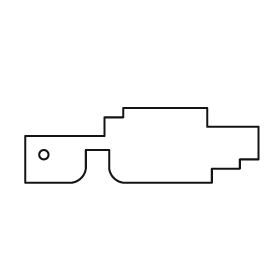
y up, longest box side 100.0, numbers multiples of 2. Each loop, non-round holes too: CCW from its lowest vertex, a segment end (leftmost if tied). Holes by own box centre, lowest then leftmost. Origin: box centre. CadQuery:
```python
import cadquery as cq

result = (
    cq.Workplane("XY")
    .moveTo(-50.0, -16.0)
    .lineTo(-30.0, -16.0)
    .threePointArc((-26.0, -14.0), (-24.0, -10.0))
    .lineTo(-24.0, -2.0)
    .lineTo(-14.0, -2.0)
    .lineTo(-14.0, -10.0)
    .threePointArc((-12.0, -14.0), (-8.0, -16.0))
    .lineTo(30.0, -16.0)
    .lineTo(30.0, -10.0)
    .lineTo(42.0, -10.0)
    .lineTo(42.0, -6.0)
    .lineTo(50.0, -6.0)
    .lineTo(50.0, 8.0)
    .lineTo(28.0, 8.0)
    .lineTo(28.0, 16.0)
    .lineTo(-8.0, 16.0)
    .lineTo(-8.0, 12.0)
    .lineTo(-16.0, 12.0)
    .lineTo(-16.0, 4.0)
    .lineTo(-50.0, 4.0)
    .close()
    .moveTo(-42.0, -4.0)
    .circle(2.0)
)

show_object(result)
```